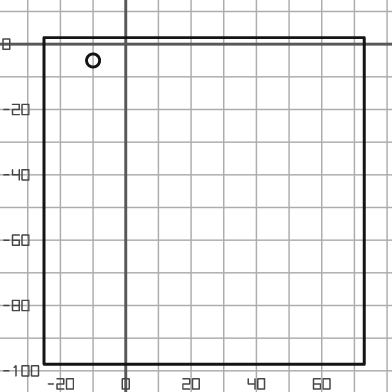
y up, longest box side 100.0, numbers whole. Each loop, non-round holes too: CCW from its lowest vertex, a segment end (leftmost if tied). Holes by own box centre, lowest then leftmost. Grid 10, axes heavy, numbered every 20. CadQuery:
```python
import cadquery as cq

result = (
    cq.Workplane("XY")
    .moveTo(-25.0, -98.0)
    .lineTo(73.0, -98.0)
    .lineTo(73.0, 2.0)
    .lineTo(-25.0, 2.0)
    .close()
    .moveTo(-10.0, -5.0)
    .circle(2.0)
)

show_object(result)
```